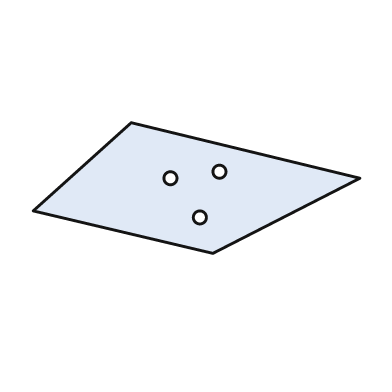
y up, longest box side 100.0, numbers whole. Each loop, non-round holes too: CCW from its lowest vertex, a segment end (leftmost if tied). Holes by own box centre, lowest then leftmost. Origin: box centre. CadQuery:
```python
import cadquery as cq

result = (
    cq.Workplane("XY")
    .moveTo(5.0, -20.0)
    .lineTo(50.0, 3.0)
    .lineTo(-20.0, 20.0)
    .lineTo(-50.0, -7.0)
    .close()
    .moveTo(1.0, -9.0)
    .circle(2.0)
    .moveTo(-8.0, 3.0)
    .circle(2.0)
    .moveTo(7.0, 5.0)
    .circle(2.0)
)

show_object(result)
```